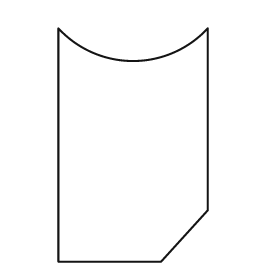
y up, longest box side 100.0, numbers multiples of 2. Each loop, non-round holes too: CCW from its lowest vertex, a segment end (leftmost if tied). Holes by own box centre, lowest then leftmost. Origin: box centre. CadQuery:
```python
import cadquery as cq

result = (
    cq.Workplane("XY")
    .moveTo(-32.0, -50.0)
    .lineTo(12.0, -50.0)
    .lineTo(32.0, -28.0)
    .lineTo(32.0, 50.0)
    .threePointArc((0.0, 36.0), (-32.0, 50.0))
    .close()
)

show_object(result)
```